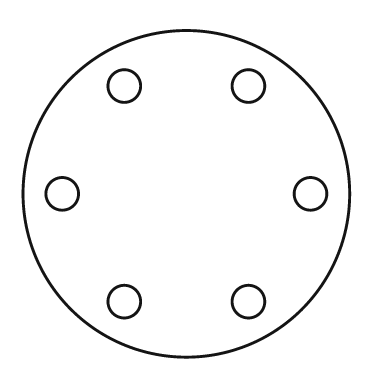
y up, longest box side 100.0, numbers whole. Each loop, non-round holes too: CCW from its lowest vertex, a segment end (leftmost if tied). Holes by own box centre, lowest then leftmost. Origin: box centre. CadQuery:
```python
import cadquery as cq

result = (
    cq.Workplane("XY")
    .moveTo(0.0, 0.0)
    .circle(50.0)
    .moveTo(-19.0, -33.0)
    .circle(5.0)
    .moveTo(19.0, -33.0)
    .circle(5.0)
    .moveTo(-38.0, 0.0)
    .circle(5.0)
    .moveTo(38.0, 0.0)
    .circle(5.0)
    .moveTo(-19.0, 33.0)
    .circle(5.0)
    .moveTo(19.0, 33.0)
    .circle(5.0)
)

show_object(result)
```